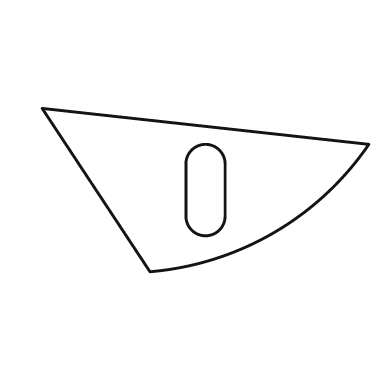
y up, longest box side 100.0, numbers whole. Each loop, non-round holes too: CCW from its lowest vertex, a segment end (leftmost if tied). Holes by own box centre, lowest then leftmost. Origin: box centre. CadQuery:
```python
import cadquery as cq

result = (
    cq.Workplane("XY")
    .moveTo(-17.0, -25.0)
    .threePointArc((21.0, -13.0), (50.0, 14.0))
    .lineTo(-50.0, 25.0)
    .close()
    .moveTo(-6.0, -8.0)
    .threePointArc((0.0, -14.0), (6.0, -8.0))
    .lineTo(6.0, 8.0)
    .threePointArc((0.0, 14.0), (-6.0, 8.0))
    .close()
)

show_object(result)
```